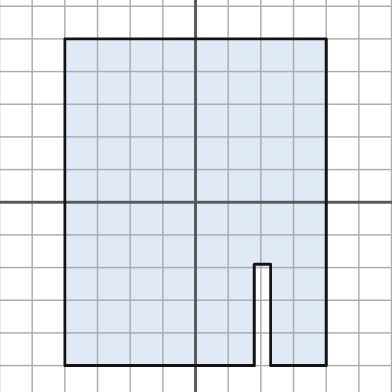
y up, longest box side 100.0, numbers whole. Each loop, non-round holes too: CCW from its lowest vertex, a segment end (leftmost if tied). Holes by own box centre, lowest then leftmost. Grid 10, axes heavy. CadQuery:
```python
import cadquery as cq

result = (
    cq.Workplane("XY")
    .moveTo(-40.0, -50.0)
    .lineTo(18.0, -50.0)
    .lineTo(18.0, -19.0)
    .lineTo(23.0, -19.0)
    .lineTo(23.0, -50.0)
    .lineTo(40.0, -50.0)
    .lineTo(40.0, 50.0)
    .lineTo(-40.0, 50.0)
    .close()
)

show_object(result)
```